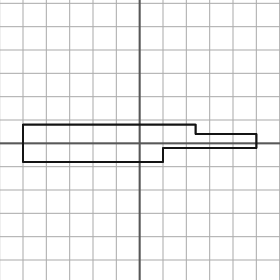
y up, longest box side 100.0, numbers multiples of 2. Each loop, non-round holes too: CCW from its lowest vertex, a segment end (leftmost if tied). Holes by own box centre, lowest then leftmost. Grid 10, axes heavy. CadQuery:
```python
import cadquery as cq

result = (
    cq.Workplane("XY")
    .moveTo(-50.0, -8.0)
    .lineTo(10.0, -8.0)
    .lineTo(10.0, -2.0)
    .lineTo(50.0, -2.0)
    .lineTo(50.0, 4.0)
    .lineTo(24.0, 4.0)
    .lineTo(24.0, 8.0)
    .lineTo(-50.0, 8.0)
    .close()
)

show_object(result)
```